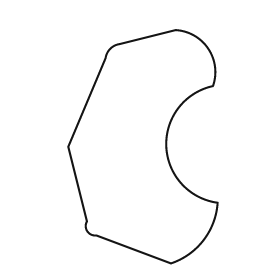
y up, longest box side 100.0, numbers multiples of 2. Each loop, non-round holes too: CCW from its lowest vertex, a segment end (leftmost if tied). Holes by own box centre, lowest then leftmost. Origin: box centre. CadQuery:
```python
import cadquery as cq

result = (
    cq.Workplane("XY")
    .moveTo(12.0, -50.0)
    .threePointArc((26.0, -40.0), (32.0, -24.0))
    .threePointArc((10.0, 0.0), (30.0, 26.0))
    .threePointArc((28.0, 42.0), (14.0, 50.0))
    .lineTo(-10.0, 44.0)
    .threePointArc((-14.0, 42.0), (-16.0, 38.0))
    .lineTo(-32.0, 0.0)
    .lineTo(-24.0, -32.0)
    .threePointArc((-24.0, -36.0), (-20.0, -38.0))
    .close()
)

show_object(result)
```